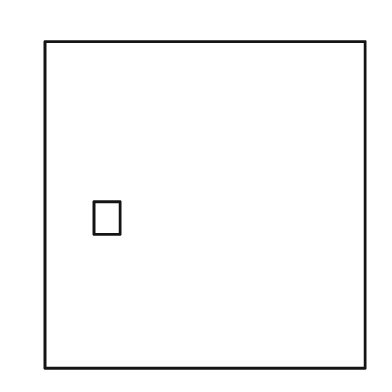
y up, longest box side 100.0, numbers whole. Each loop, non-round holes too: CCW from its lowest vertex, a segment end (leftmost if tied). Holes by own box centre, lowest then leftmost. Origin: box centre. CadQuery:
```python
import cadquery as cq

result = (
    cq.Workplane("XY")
    .moveTo(-49.0, -50.0)
    .lineTo(49.0, -50.0)
    .lineTo(49.0, 50.0)
    .lineTo(-49.0, 50.0)
    .close()
    .moveTo(-34.0, -9.0)
    .lineTo(-26.0, -9.0)
    .lineTo(-26.0, 1.0)
    .lineTo(-34.0, 1.0)
    .close()
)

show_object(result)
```